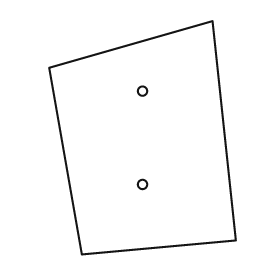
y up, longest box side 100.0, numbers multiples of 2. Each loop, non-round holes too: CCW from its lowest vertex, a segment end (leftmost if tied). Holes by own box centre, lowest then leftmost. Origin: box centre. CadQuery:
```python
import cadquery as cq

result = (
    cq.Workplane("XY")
    .moveTo(-26.0, -50.0)
    .lineTo(40.0, -44.0)
    .lineTo(30.0, 50.0)
    .lineTo(-40.0, 30.0)
    .close()
    .moveTo(0.0, -20.0)
    .circle(2.0)
    .moveTo(0.0, 20.0)
    .circle(2.0)
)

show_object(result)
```